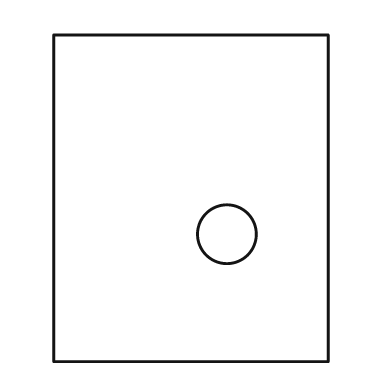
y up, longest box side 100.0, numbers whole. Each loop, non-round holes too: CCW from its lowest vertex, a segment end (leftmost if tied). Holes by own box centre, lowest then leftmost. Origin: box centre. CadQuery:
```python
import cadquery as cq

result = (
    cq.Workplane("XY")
    .moveTo(-42.0, -50.0)
    .lineTo(42.0, -50.0)
    .lineTo(42.0, 50.0)
    .lineTo(-42.0, 50.0)
    .close()
    .moveTo(11.0, -11.0)
    .circle(9.0)
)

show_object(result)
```